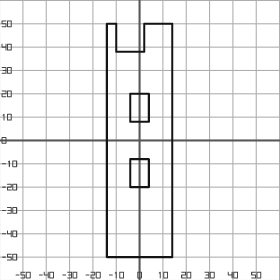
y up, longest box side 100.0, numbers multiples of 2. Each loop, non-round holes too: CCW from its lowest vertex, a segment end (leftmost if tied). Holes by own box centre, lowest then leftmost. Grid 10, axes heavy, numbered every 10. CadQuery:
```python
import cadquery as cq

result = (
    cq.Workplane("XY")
    .moveTo(-14.0, -50.0)
    .lineTo(14.0, -50.0)
    .lineTo(14.0, 50.0)
    .lineTo(2.0, 50.0)
    .lineTo(2.0, 38.0)
    .lineTo(-10.0, 38.0)
    .lineTo(-10.0, 50.0)
    .lineTo(-14.0, 50.0)
    .close()
    .moveTo(-4.0, -20.0)
    .lineTo(4.0, -20.0)
    .lineTo(4.0, -8.0)
    .lineTo(-4.0, -8.0)
    .close()
    .moveTo(-4.0, 8.0)
    .lineTo(4.0, 8.0)
    .lineTo(4.0, 20.0)
    .lineTo(-4.0, 20.0)
    .close()
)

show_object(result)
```